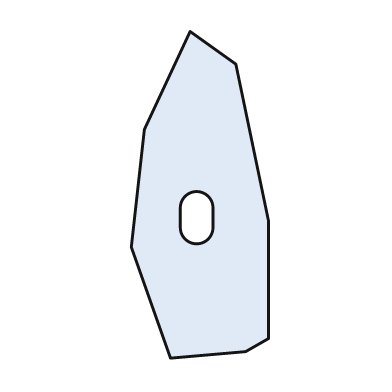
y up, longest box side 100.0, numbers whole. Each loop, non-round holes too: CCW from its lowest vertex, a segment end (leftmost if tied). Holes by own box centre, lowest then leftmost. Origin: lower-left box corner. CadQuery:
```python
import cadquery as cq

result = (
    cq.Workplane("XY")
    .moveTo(12.0, 0.0)
    .lineTo(35.0, 2.0)
    .lineTo(42.0, 6.0)
    .lineTo(42.0, 42.0)
    .lineTo(32.0, 90.0)
    .lineTo(18.0, 100.0)
    .lineTo(4.0, 70.0)
    .lineTo(0.0, 34.0)
    .close()
    .moveTo(15.0, 40.0)
    .threePointArc((20.0, 35.0), (25.0, 40.0))
    .lineTo(25.0, 46.0)
    .threePointArc((20.0, 51.0), (15.0, 46.0))
    .close()
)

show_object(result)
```